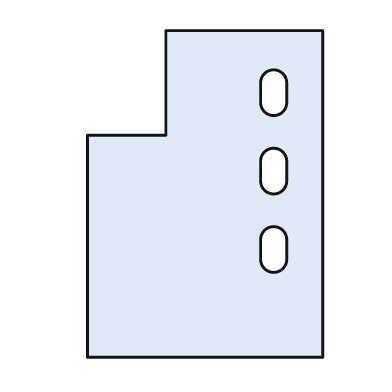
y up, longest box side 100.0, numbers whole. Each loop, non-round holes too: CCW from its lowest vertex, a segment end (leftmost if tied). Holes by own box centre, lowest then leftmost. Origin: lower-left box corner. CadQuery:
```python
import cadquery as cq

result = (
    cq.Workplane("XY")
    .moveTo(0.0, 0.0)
    .lineTo(72.0, 0.0)
    .lineTo(72.0, 100.0)
    .lineTo(24.0, 100.0)
    .lineTo(24.0, 68.0)
    .lineTo(0.0, 68.0)
    .close()
    .moveTo(53.0, 30.0)
    .threePointArc((57.0, 26.0), (61.0, 30.0))
    .lineTo(61.0, 36.0)
    .threePointArc((57.0, 40.0), (53.0, 36.0))
    .close()
    .moveTo(53.0, 54.0)
    .threePointArc((57.0, 50.0), (61.0, 54.0))
    .lineTo(61.0, 60.0)
    .threePointArc((57.0, 64.0), (53.0, 60.0))
    .close()
    .moveTo(53.0, 78.0)
    .threePointArc((57.0, 74.0), (61.0, 78.0))
    .lineTo(61.0, 84.0)
    .threePointArc((57.0, 88.0), (53.0, 84.0))
    .close()
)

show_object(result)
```